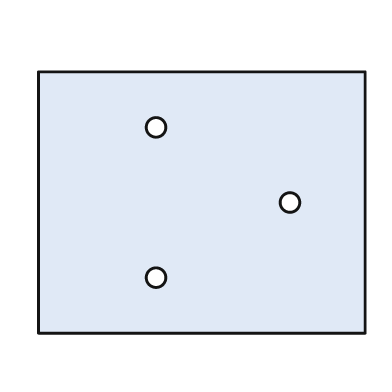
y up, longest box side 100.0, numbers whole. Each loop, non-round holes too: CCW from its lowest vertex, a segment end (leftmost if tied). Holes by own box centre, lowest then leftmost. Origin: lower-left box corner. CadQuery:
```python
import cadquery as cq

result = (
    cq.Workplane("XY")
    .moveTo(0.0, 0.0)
    .lineTo(100.0, 0.0)
    .lineTo(100.0, 80.0)
    .lineTo(0.0, 80.0)
    .close()
    .moveTo(36.0, 17.0)
    .circle(3.0)
    .moveTo(77.0, 40.0)
    .circle(3.0)
    .moveTo(36.0, 63.0)
    .circle(3.0)
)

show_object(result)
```